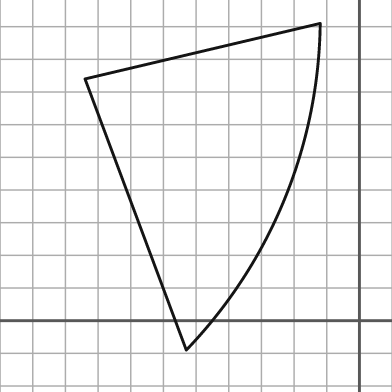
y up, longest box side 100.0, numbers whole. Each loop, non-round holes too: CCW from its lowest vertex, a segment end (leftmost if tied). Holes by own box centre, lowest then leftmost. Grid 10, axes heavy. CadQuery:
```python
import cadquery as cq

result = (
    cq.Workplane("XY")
    .moveTo(-53.0, -9.0)
    .threePointArc((-23.0, 37.0), (-12.0, 91.0))
    .lineTo(-84.0, 74.0)
    .close()
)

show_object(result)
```